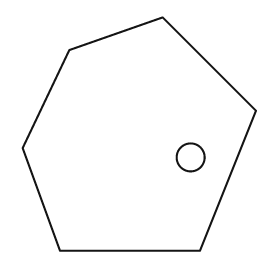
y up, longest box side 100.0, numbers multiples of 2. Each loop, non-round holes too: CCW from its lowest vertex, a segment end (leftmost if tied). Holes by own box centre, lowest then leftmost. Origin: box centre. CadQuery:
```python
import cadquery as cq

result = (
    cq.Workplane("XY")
    .moveTo(-34.0, -50.0)
    .lineTo(26.0, -50.0)
    .lineTo(50.0, 10.0)
    .lineTo(10.0, 50.0)
    .lineTo(-30.0, 36.0)
    .lineTo(-50.0, -6.0)
    .close()
    .moveTo(22.0, -10.0)
    .circle(6.0)
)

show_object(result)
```